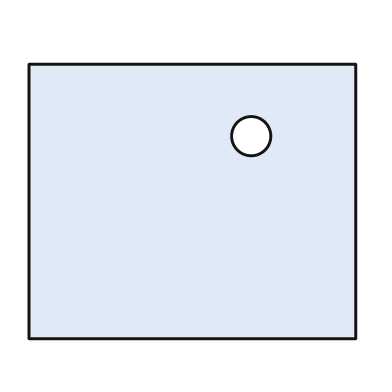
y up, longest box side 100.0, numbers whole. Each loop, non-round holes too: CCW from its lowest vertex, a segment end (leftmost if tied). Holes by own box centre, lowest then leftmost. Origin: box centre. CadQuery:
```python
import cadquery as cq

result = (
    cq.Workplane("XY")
    .moveTo(-50.0, -42.0)
    .lineTo(50.0, -42.0)
    .lineTo(50.0, 42.0)
    .lineTo(-50.0, 42.0)
    .close()
    .moveTo(18.0, 20.0)
    .circle(6.0)
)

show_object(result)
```